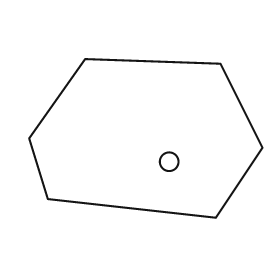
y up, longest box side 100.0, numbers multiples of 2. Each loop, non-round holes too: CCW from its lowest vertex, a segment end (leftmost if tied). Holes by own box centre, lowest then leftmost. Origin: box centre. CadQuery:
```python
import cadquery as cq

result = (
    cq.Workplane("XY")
    .moveTo(30.0, -34.0)
    .lineTo(50.0, -4.0)
    .lineTo(32.0, 32.0)
    .lineTo(-26.0, 34.0)
    .lineTo(-50.0, 0.0)
    .lineTo(-42.0, -26.0)
    .close()
    .moveTo(10.0, -10.0)
    .circle(4.0)
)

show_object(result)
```